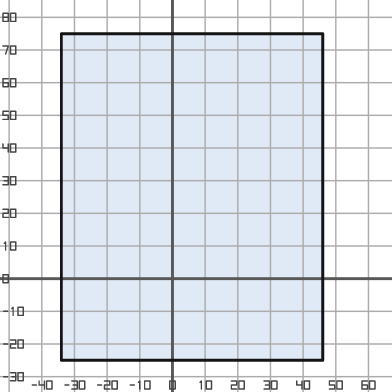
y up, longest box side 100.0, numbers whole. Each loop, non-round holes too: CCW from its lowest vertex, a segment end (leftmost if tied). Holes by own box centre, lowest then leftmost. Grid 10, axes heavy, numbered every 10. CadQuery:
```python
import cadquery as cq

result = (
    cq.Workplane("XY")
    .moveTo(-34.0, -25.0)
    .lineTo(46.0, -25.0)
    .lineTo(46.0, 75.0)
    .lineTo(-34.0, 75.0)
    .close()
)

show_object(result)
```